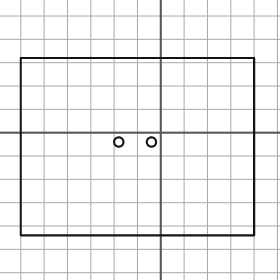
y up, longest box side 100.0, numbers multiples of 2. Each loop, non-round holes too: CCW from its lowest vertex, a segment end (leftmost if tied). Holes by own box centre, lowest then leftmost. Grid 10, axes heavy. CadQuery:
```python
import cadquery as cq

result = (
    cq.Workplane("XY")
    .moveTo(-60.0, -44.0)
    .lineTo(40.0, -44.0)
    .lineTo(40.0, 32.0)
    .lineTo(-60.0, 32.0)
    .close()
    .moveTo(-18.0, -4.0)
    .circle(2.0)
    .moveTo(-4.0, -4.0)
    .circle(2.0)
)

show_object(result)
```